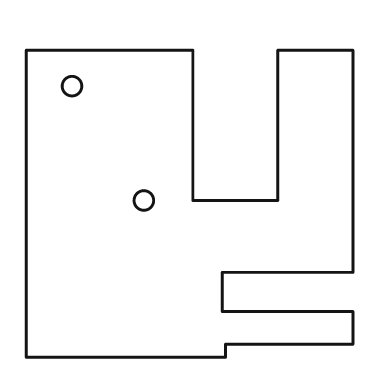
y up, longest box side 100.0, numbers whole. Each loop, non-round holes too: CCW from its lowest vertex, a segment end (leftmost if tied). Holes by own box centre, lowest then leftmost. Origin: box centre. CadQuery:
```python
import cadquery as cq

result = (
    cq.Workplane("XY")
    .moveTo(-50.0, -47.0)
    .lineTo(11.0, -47.0)
    .lineTo(11.0, -43.0)
    .lineTo(50.0, -43.0)
    .lineTo(50.0, -33.0)
    .lineTo(10.0, -33.0)
    .lineTo(10.0, -21.0)
    .lineTo(50.0, -21.0)
    .lineTo(50.0, 47.0)
    .lineTo(27.0, 47.0)
    .lineTo(27.0, 1.0)
    .lineTo(1.0, 1.0)
    .lineTo(1.0, 47.0)
    .lineTo(-50.0, 47.0)
    .close()
    .moveTo(-14.0, 1.0)
    .circle(3.0)
    .moveTo(-36.0, 36.0)
    .circle(3.0)
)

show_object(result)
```